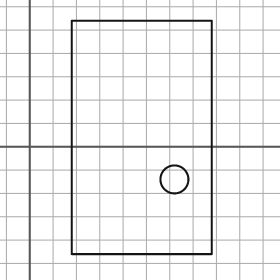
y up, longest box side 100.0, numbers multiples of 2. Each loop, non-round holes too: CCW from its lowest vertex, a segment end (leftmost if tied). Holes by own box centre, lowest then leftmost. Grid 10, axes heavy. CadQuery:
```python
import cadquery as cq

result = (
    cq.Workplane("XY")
    .moveTo(18.0, -46.0)
    .lineTo(78.0, -46.0)
    .lineTo(78.0, 54.0)
    .lineTo(18.0, 54.0)
    .close()
    .moveTo(62.0, -14.0)
    .circle(6.0)
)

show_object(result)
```